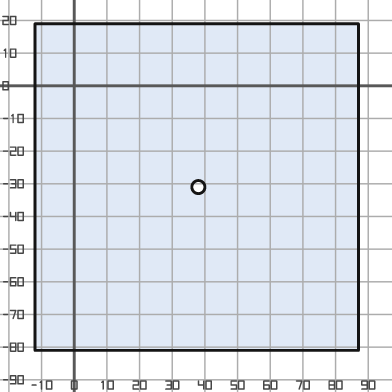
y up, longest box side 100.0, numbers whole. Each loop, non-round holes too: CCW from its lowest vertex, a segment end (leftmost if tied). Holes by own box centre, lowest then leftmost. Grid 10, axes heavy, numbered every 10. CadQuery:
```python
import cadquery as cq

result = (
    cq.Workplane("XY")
    .moveTo(-12.0, -81.0)
    .lineTo(87.0, -81.0)
    .lineTo(87.0, 19.0)
    .lineTo(-12.0, 19.0)
    .close()
    .moveTo(38.0, -31.0)
    .circle(2.0)
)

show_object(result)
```